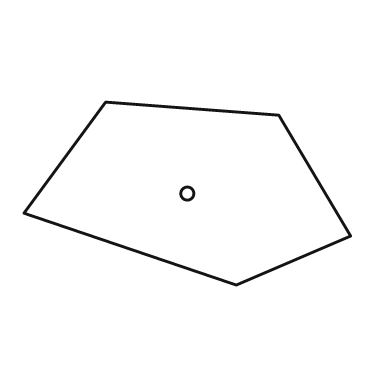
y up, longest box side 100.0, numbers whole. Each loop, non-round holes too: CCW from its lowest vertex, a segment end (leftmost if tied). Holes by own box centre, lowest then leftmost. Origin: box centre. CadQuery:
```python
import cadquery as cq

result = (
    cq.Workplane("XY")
    .moveTo(15.0, -28.0)
    .lineTo(50.0, -13.0)
    .lineTo(28.0, 24.0)
    .lineTo(-25.0, 28.0)
    .lineTo(-50.0, -6.0)
    .close()
    .moveTo(0.0, 0.0)
    .circle(2.0)
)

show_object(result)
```